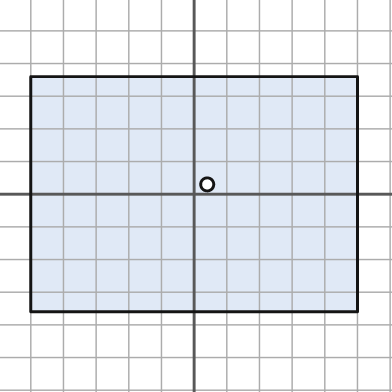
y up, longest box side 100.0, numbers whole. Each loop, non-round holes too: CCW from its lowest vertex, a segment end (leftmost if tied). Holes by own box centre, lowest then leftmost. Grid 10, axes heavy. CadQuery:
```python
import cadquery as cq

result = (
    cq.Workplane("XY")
    .moveTo(-50.0, -36.0)
    .lineTo(50.0, -36.0)
    .lineTo(50.0, 36.0)
    .lineTo(-50.0, 36.0)
    .close()
    .moveTo(4.0, 3.0)
    .circle(2.0)
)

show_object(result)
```